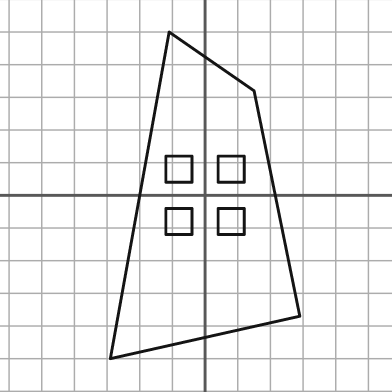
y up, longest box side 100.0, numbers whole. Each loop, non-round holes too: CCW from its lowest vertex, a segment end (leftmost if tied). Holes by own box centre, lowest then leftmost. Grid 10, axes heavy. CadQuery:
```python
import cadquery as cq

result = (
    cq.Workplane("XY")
    .moveTo(-29.0, -50.0)
    .lineTo(29.0, -37.0)
    .lineTo(15.0, 32.0)
    .lineTo(-11.0, 50.0)
    .close()
    .moveTo(-12.0, -12.0)
    .lineTo(-4.0, -12.0)
    .lineTo(-4.0, -4.0)
    .lineTo(-12.0, -4.0)
    .close()
    .moveTo(4.0, -12.0)
    .lineTo(12.0, -12.0)
    .lineTo(12.0, -4.0)
    .lineTo(4.0, -4.0)
    .close()
    .moveTo(-12.0, 4.0)
    .lineTo(-4.0, 4.0)
    .lineTo(-4.0, 12.0)
    .lineTo(-12.0, 12.0)
    .close()
    .moveTo(4.0, 4.0)
    .lineTo(12.0, 4.0)
    .lineTo(12.0, 12.0)
    .lineTo(4.0, 12.0)
    .close()
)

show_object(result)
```